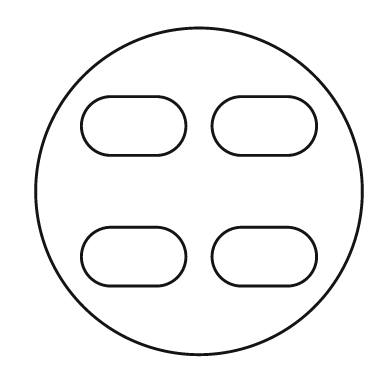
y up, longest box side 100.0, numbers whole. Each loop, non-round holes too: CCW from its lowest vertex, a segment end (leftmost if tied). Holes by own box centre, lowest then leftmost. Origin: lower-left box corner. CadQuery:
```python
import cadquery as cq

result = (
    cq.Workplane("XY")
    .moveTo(50.0, 50.0)
    .circle(50.0)
    .moveTo(23.0, 21.0)
    .lineTo(37.0, 21.0)
    .threePointArc((46.0, 30.0), (37.0, 39.0))
    .lineTo(23.0, 39.0)
    .threePointArc((14.0, 30.0), (23.0, 21.0))
    .close()
    .moveTo(63.0, 21.0)
    .lineTo(77.0, 21.0)
    .threePointArc((86.0, 30.0), (77.0, 39.0))
    .lineTo(63.0, 39.0)
    .threePointArc((54.0, 30.0), (63.0, 21.0))
    .close()
    .moveTo(23.0, 61.0)
    .lineTo(37.0, 61.0)
    .threePointArc((46.0, 70.0), (37.0, 79.0))
    .lineTo(23.0, 79.0)
    .threePointArc((14.0, 70.0), (23.0, 61.0))
    .close()
    .moveTo(63.0, 61.0)
    .lineTo(77.0, 61.0)
    .threePointArc((86.0, 70.0), (77.0, 79.0))
    .lineTo(63.0, 79.0)
    .threePointArc((54.0, 70.0), (63.0, 61.0))
    .close()
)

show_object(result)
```